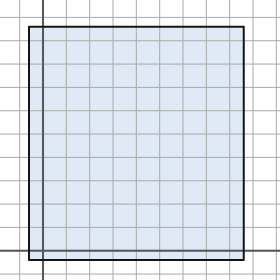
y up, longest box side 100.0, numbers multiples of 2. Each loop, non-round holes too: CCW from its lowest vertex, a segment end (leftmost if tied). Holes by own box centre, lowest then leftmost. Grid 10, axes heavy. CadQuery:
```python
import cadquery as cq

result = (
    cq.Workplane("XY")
    .moveTo(-6.0, -4.0)
    .lineTo(86.0, -4.0)
    .lineTo(86.0, 96.0)
    .lineTo(-6.0, 96.0)
    .close()
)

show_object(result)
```